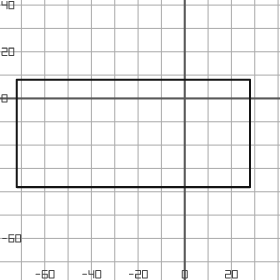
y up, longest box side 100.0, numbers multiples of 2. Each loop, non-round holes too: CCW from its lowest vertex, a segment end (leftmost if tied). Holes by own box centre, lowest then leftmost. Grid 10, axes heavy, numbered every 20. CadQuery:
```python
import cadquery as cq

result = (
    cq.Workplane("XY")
    .moveTo(-72.0, -38.0)
    .lineTo(28.0, -38.0)
    .lineTo(28.0, 8.0)
    .lineTo(-72.0, 8.0)
    .close()
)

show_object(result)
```